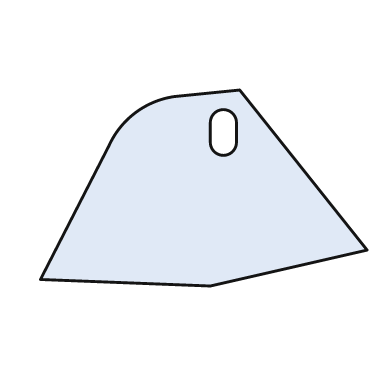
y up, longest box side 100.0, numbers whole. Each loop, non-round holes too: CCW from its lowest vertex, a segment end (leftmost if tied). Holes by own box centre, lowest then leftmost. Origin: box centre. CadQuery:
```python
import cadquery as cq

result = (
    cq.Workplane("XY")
    .moveTo(2.0, -30.0)
    .lineTo(50.0, -19.0)
    .lineTo(11.0, 30.0)
    .lineTo(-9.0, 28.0)
    .threePointArc((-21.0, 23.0), (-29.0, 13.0))
    .lineTo(-50.0, -28.0)
    .close()
    .moveTo(2.0, 14.0)
    .threePointArc((6.0, 10.0), (10.0, 14.0))
    .lineTo(10.0, 20.0)
    .threePointArc((6.0, 24.0), (2.0, 20.0))
    .close()
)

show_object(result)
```